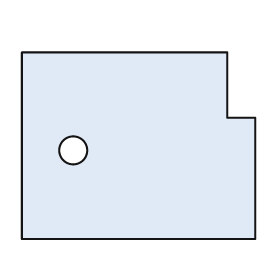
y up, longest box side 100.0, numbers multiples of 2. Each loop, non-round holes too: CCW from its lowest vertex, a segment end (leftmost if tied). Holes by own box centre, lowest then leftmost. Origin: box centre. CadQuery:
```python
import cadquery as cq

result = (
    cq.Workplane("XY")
    .moveTo(-50.0, -40.0)
    .lineTo(50.0, -40.0)
    .lineTo(50.0, 12.0)
    .lineTo(38.0, 12.0)
    .lineTo(38.0, 40.0)
    .lineTo(-50.0, 40.0)
    .close()
    .moveTo(-28.0, -2.0)
    .circle(6.0)
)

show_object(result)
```